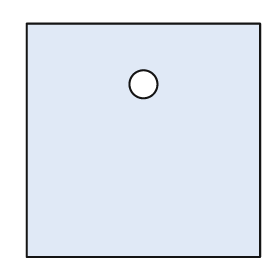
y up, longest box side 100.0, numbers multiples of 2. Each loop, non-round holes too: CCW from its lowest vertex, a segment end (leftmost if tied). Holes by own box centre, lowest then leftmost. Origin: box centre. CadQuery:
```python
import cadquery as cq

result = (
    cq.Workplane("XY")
    .moveTo(-50.0, -50.0)
    .lineTo(50.0, -50.0)
    .lineTo(50.0, 50.0)
    .lineTo(-50.0, 50.0)
    .close()
    .moveTo(0.0, 24.0)
    .circle(6.0)
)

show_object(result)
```